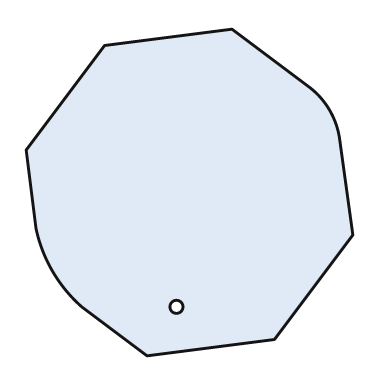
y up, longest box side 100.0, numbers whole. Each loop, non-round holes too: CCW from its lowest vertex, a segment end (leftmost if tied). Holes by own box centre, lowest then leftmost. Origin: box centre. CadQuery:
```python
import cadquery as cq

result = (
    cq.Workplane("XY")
    .moveTo(-13.0, -50.0)
    .lineTo(26.0, -45.0)
    .lineTo(50.0, -13.0)
    .lineTo(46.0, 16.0)
    .threePointArc((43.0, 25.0), (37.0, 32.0))
    .lineTo(13.0, 50.0)
    .lineTo(-26.0, 45.0)
    .lineTo(-50.0, 13.0)
    .lineTo(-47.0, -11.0)
    .threePointArc((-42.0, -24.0), (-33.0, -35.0))
    .close()
    .moveTo(-4.0, -35.0)
    .circle(2.0)
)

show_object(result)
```